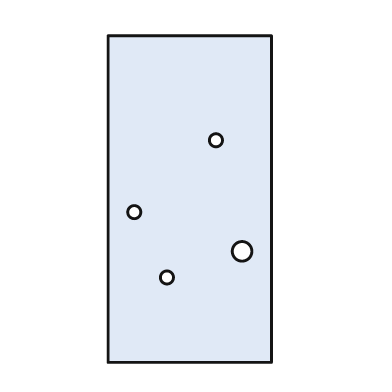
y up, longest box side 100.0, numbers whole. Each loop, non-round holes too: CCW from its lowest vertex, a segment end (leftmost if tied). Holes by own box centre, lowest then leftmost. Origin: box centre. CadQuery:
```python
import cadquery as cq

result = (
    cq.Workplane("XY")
    .moveTo(-25.0, -50.0)
    .lineTo(25.0, -50.0)
    .lineTo(25.0, 50.0)
    .lineTo(-25.0, 50.0)
    .close()
    .moveTo(-7.0, -24.0)
    .circle(2.0)
    .moveTo(16.0, -16.0)
    .circle(3.0)
    .moveTo(-17.0, -4.0)
    .circle(2.0)
    .moveTo(8.0, 18.0)
    .circle(2.0)
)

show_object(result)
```